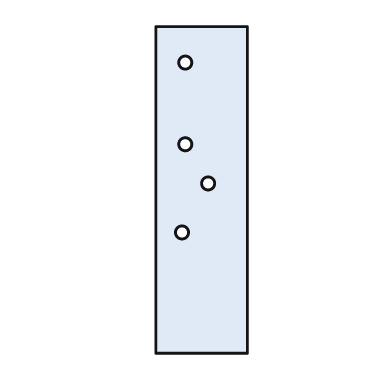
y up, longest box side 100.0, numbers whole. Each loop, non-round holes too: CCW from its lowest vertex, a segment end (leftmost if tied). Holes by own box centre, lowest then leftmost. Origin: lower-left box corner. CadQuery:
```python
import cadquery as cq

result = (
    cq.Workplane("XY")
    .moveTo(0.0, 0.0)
    .lineTo(28.0, 0.0)
    .lineTo(28.0, 100.0)
    .lineTo(0.0, 100.0)
    .close()
    .moveTo(8.0, 37.0)
    .circle(2.0)
    .moveTo(16.0, 52.0)
    .circle(2.0)
    .moveTo(9.0, 64.0)
    .circle(2.0)
    .moveTo(9.0, 89.0)
    .circle(2.0)
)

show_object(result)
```